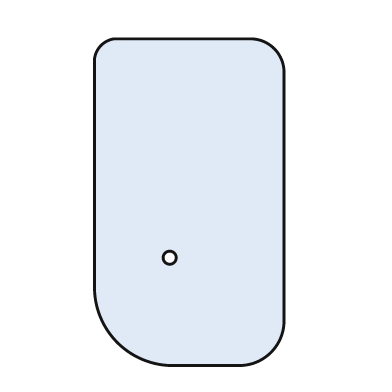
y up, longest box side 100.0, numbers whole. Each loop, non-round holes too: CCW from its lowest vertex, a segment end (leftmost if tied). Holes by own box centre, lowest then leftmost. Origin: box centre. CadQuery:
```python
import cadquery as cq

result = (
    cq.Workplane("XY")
    .moveTo(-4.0, -50.0)
    .lineTo(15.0, -50.0)
    .threePointArc((25.0, -46.0), (29.0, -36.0))
    .lineTo(29.0, 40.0)
    .threePointArc((26.0, 47.0), (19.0, 50.0))
    .lineTo(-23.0, 50.0)
    .threePointArc((-27.0, 48.0), (-29.0, 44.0))
    .lineTo(-29.0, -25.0)
    .threePointArc((-22.0, -43.0), (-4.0, -50.0))
    .close()
    .moveTo(-6.0, -17.0)
    .circle(2.0)
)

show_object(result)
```